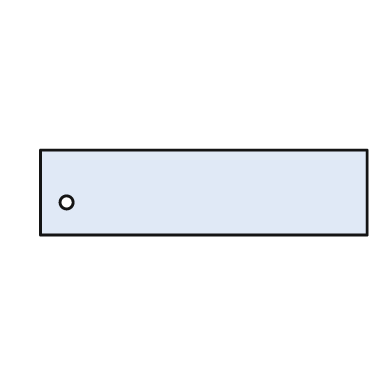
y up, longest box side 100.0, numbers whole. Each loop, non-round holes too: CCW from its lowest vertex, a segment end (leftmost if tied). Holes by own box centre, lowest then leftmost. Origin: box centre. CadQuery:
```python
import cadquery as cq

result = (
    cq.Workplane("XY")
    .moveTo(-50.0, -13.0)
    .lineTo(50.0, -13.0)
    .lineTo(50.0, 13.0)
    .lineTo(-50.0, 13.0)
    .close()
    .moveTo(-42.0, -3.0)
    .circle(2.0)
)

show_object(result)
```